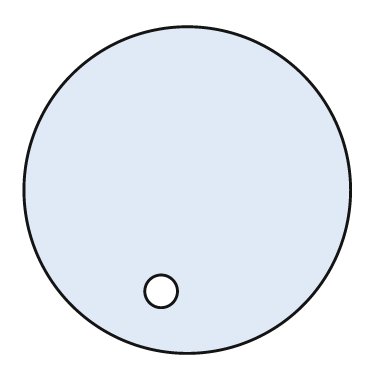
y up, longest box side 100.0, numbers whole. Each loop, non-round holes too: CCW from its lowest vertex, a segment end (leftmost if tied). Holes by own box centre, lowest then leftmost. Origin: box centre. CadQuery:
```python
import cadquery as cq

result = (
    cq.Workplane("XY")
    .moveTo(0.0, 0.0)
    .circle(50.0)
    .moveTo(-8.0, -31.0)
    .circle(5.0)
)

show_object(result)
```